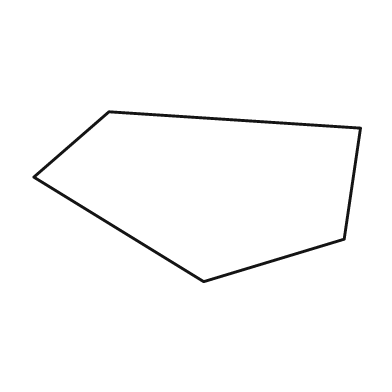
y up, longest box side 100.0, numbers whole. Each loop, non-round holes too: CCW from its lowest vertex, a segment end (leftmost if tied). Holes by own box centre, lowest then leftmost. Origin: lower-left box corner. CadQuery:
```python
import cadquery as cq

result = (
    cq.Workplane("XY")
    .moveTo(52.0, 0.0)
    .lineTo(95.0, 13.0)
    .lineTo(100.0, 47.0)
    .lineTo(23.0, 52.0)
    .lineTo(0.0, 32.0)
    .close()
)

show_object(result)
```